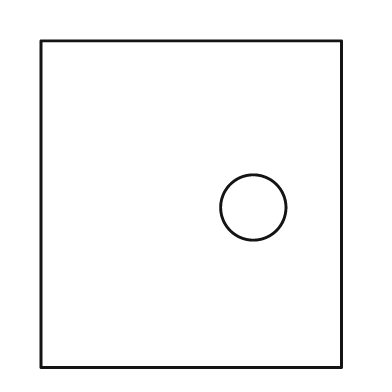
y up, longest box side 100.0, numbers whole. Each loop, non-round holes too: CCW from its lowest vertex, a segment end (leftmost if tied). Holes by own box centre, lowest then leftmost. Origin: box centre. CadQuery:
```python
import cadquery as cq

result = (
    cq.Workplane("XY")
    .moveTo(-46.0, -50.0)
    .lineTo(46.0, -50.0)
    .lineTo(46.0, 50.0)
    .lineTo(-46.0, 50.0)
    .close()
    .moveTo(19.0, -1.0)
    .circle(10.0)
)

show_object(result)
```